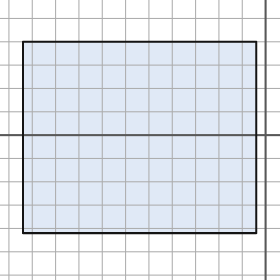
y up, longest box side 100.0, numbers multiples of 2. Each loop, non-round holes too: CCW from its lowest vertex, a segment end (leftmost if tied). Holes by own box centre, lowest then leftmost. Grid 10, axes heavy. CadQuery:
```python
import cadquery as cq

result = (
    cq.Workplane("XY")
    .moveTo(-104.0, -42.0)
    .lineTo(-4.0, -42.0)
    .lineTo(-4.0, 40.0)
    .lineTo(-104.0, 40.0)
    .close()
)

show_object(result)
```